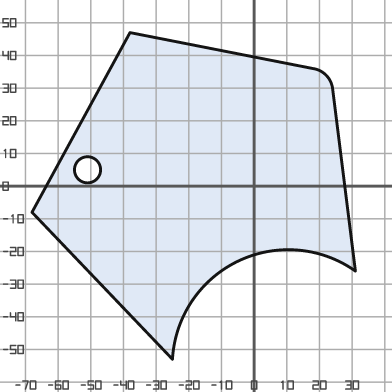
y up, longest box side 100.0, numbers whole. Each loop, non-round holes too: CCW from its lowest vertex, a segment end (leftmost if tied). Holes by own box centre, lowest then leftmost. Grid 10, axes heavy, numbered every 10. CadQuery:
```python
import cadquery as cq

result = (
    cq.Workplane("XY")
    .moveTo(-25.0, -53.0)
    .threePointArc((-5.0, -23.0), (31.0, -26.0))
    .lineTo(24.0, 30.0)
    .threePointArc((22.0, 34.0), (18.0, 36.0))
    .lineTo(-38.0, 47.0)
    .lineTo(-68.0, -8.0)
    .close()
    .moveTo(-51.0, 5.0)
    .circle(4.0)
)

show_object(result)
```